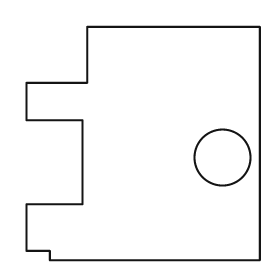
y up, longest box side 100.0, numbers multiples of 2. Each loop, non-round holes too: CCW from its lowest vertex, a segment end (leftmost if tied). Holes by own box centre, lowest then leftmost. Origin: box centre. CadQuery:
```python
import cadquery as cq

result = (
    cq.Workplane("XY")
    .moveTo(-40.0, -50.0)
    .lineTo(50.0, -50.0)
    .lineTo(50.0, 50.0)
    .lineTo(-24.0, 50.0)
    .lineTo(-24.0, 26.0)
    .lineTo(-50.0, 26.0)
    .lineTo(-50.0, 10.0)
    .lineTo(-26.0, 10.0)
    .lineTo(-26.0, -26.0)
    .lineTo(-50.0, -26.0)
    .lineTo(-50.0, -46.0)
    .lineTo(-40.0, -46.0)
    .close()
    .moveTo(34.0, -6.0)
    .circle(12.0)
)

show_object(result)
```